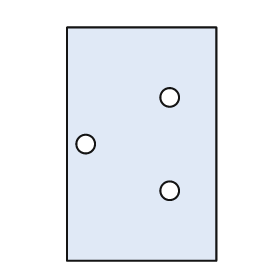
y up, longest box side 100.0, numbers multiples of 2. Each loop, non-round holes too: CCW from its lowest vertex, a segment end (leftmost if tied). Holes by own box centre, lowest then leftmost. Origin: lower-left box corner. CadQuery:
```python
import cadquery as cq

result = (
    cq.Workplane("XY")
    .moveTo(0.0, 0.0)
    .lineTo(64.0, 0.0)
    .lineTo(64.0, 100.0)
    .lineTo(0.0, 100.0)
    .close()
    .moveTo(44.0, 30.0)
    .circle(4.0)
    .moveTo(8.0, 50.0)
    .circle(4.0)
    .moveTo(44.0, 70.0)
    .circle(4.0)
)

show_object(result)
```